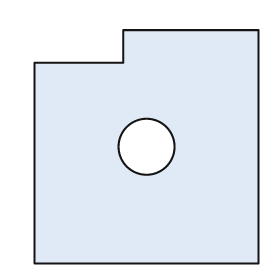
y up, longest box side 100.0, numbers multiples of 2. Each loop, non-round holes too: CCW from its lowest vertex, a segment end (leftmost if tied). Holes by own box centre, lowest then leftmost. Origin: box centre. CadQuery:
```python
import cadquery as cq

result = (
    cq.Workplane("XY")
    .moveTo(-48.0, -50.0)
    .lineTo(48.0, -50.0)
    .lineTo(48.0, 50.0)
    .lineTo(-10.0, 50.0)
    .lineTo(-10.0, 36.0)
    .lineTo(-48.0, 36.0)
    .close()
    .moveTo(0.0, 0.0)
    .circle(12.0)
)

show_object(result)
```